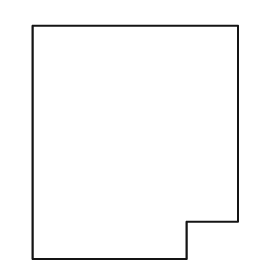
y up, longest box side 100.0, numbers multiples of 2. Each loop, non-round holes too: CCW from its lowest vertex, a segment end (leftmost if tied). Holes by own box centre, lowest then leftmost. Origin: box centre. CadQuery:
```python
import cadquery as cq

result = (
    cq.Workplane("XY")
    .moveTo(-44.0, -50.0)
    .lineTo(22.0, -50.0)
    .lineTo(22.0, -34.0)
    .lineTo(44.0, -34.0)
    .lineTo(44.0, 50.0)
    .lineTo(-44.0, 50.0)
    .close()
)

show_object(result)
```